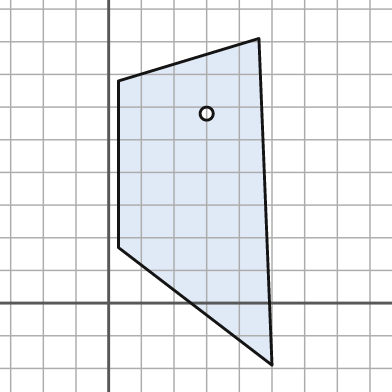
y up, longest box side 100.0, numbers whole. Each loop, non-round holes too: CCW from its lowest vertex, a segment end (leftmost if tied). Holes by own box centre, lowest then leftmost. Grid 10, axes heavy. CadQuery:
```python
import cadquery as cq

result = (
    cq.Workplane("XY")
    .moveTo(50.0, -19.0)
    .lineTo(46.0, 81.0)
    .lineTo(3.0, 68.0)
    .lineTo(3.0, 17.0)
    .close()
    .moveTo(30.0, 58.0)
    .circle(2.0)
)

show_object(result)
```